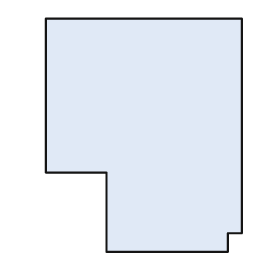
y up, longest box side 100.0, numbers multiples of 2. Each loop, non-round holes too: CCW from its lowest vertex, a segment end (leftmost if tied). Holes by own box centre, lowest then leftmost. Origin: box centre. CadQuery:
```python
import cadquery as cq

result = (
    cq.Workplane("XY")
    .moveTo(-16.0, -50.0)
    .lineTo(36.0, -50.0)
    .lineTo(36.0, -42.0)
    .lineTo(42.0, -42.0)
    .lineTo(42.0, 50.0)
    .lineTo(-42.0, 50.0)
    .lineTo(-42.0, -16.0)
    .lineTo(-16.0, -16.0)
    .close()
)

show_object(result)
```